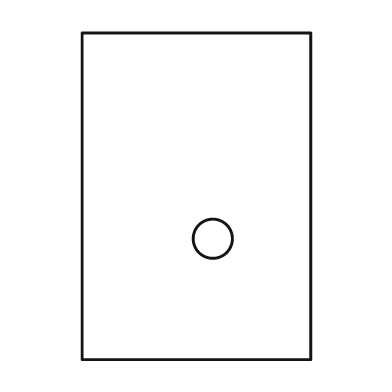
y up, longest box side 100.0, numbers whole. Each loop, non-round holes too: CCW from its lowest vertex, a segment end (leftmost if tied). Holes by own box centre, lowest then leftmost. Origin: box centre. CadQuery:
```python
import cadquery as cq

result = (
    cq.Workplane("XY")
    .moveTo(-35.0, -50.0)
    .lineTo(35.0, -50.0)
    .lineTo(35.0, 50.0)
    .lineTo(-35.0, 50.0)
    .close()
    .moveTo(5.0, -13.0)
    .circle(6.0)
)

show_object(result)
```